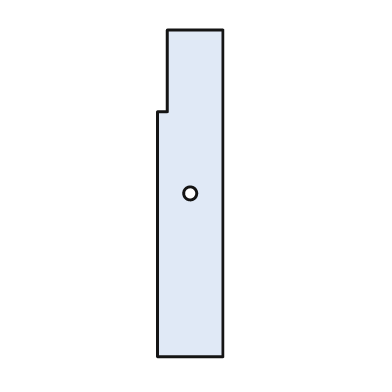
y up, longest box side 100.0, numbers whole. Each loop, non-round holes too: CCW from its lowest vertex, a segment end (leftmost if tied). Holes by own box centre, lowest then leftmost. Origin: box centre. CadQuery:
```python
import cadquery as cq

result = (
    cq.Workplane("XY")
    .moveTo(-10.0, -50.0)
    .lineTo(10.0, -50.0)
    .lineTo(10.0, 50.0)
    .lineTo(-7.0, 50.0)
    .lineTo(-7.0, 25.0)
    .lineTo(-10.0, 25.0)
    .close()
    .moveTo(0.0, 0.0)
    .circle(2.0)
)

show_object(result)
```